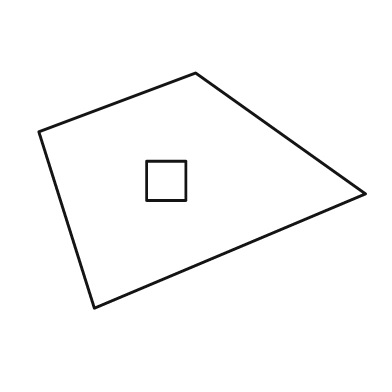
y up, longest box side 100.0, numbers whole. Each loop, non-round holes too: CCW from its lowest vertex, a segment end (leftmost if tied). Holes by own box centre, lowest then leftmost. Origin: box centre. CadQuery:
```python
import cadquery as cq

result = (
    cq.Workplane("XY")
    .moveTo(-33.0, -36.0)
    .lineTo(50.0, -1.0)
    .lineTo(-2.0, 36.0)
    .lineTo(-50.0, 18.0)
    .close()
    .moveTo(-17.0, -3.0)
    .lineTo(-5.0, -3.0)
    .lineTo(-5.0, 9.0)
    .lineTo(-17.0, 9.0)
    .close()
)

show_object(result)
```